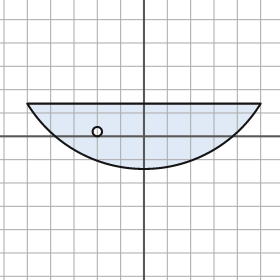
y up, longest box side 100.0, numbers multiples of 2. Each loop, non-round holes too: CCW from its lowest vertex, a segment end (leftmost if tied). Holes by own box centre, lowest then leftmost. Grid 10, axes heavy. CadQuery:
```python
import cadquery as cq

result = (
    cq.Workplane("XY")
    .moveTo(-50.0, 14.0)
    .threePointArc((0.0, -14.0), (50.0, 14.0))
    .close()
    .moveTo(-20.0, 2.0)
    .circle(2.0)
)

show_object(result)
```